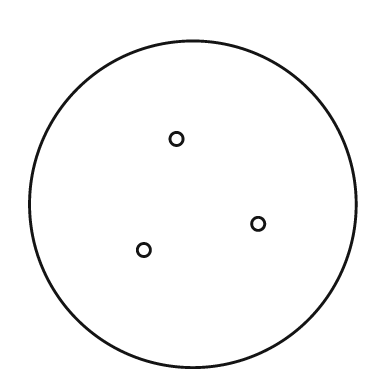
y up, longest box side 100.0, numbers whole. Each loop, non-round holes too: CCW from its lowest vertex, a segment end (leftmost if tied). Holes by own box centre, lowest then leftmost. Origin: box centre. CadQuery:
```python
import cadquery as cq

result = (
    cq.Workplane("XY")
    .moveTo(0.0, 0.0)
    .circle(50.0)
    .moveTo(-15.0, -14.0)
    .circle(2.0)
    .moveTo(20.0, -6.0)
    .circle(2.0)
    .moveTo(-5.0, 20.0)
    .circle(2.0)
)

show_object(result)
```